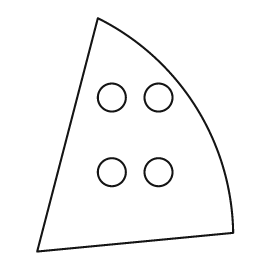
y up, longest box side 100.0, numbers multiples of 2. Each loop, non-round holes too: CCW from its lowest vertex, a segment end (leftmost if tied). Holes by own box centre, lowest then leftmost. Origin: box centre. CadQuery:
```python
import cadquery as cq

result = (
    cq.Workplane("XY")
    .moveTo(-42.0, -50.0)
    .lineTo(42.0, -42.0)
    .threePointArc((26.0, 12.0), (-16.0, 50.0))
    .close()
    .moveTo(-10.0, -16.0)
    .circle(6.0)
    .moveTo(10.0, -16.0)
    .circle(6.0)
    .moveTo(-10.0, 16.0)
    .circle(6.0)
    .moveTo(10.0, 16.0)
    .circle(6.0)
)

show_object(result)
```